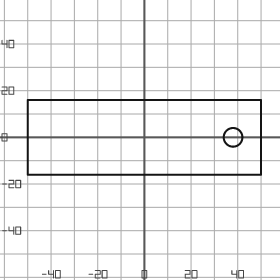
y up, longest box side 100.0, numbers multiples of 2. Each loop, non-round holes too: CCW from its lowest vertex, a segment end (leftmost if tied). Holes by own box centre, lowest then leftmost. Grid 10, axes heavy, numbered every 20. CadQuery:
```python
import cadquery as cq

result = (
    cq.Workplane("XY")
    .moveTo(-50.0, -16.0)
    .lineTo(50.0, -16.0)
    .lineTo(50.0, 16.0)
    .lineTo(-50.0, 16.0)
    .close()
    .moveTo(38.0, 0.0)
    .circle(4.0)
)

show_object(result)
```